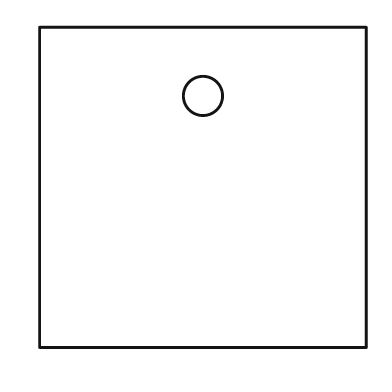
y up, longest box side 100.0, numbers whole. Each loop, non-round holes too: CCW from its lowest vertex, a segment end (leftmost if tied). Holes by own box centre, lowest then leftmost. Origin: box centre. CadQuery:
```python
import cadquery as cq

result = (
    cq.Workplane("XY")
    .moveTo(-50.0, -49.0)
    .lineTo(50.0, -49.0)
    .lineTo(50.0, 49.0)
    .lineTo(-50.0, 49.0)
    .close()
    .moveTo(0.0, 28.0)
    .circle(6.0)
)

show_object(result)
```